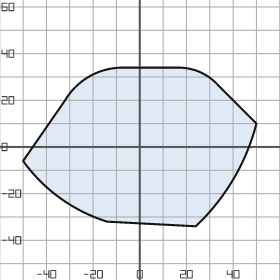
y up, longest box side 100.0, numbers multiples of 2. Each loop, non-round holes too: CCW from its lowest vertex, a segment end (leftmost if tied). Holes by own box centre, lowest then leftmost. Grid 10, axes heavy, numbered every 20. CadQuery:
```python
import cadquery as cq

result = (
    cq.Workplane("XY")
    .moveTo(24.0, -34.0)
    .threePointArc((40.0, -14.0), (50.0, 10.0))
    .lineTo(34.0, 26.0)
    .threePointArc((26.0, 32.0), (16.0, 34.0))
    .lineTo(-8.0, 34.0)
    .threePointArc((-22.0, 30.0), (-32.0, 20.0))
    .lineTo(-50.0, -6.0)
    .threePointArc((-34.0, -22.0), (-14.0, -32.0))
    .close()
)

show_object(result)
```